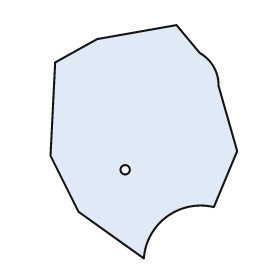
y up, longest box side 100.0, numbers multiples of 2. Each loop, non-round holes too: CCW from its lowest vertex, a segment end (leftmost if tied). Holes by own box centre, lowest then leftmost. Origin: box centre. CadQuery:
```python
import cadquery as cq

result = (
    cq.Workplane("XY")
    .moveTo(0.0, -50.0)
    .threePointArc((10.0, -32.0), (30.0, -28.0))
    .lineTo(40.0, -4.0)
    .lineTo(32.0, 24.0)
    .threePointArc((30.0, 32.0), (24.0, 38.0))
    .lineTo(14.0, 50.0)
    .lineTo(-20.0, 44.0)
    .lineTo(-38.0, 34.0)
    .lineTo(-40.0, -6.0)
    .lineTo(-28.0, -30.0)
    .close()
    .moveTo(-8.0, -12.0)
    .circle(2.0)
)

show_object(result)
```